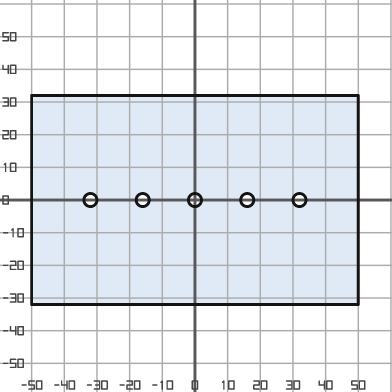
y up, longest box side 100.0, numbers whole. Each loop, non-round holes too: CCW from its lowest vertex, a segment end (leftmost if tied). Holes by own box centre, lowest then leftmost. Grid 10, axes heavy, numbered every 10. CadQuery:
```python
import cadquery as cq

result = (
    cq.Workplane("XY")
    .moveTo(-50.0, -32.0)
    .lineTo(50.0, -32.0)
    .lineTo(50.0, 32.0)
    .lineTo(-50.0, 32.0)
    .close()
    .moveTo(-32.0, 0.0)
    .circle(2.0)
    .moveTo(-16.0, 0.0)
    .circle(2.0)
    .moveTo(0.0, 0.0)
    .circle(2.0)
    .moveTo(16.0, 0.0)
    .circle(2.0)
    .moveTo(32.0, 0.0)
    .circle(2.0)
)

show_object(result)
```